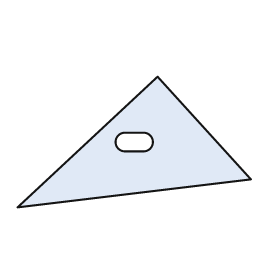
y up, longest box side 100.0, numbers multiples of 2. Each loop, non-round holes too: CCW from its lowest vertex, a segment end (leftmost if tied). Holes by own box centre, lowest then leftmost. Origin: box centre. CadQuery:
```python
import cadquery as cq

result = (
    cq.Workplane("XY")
    .moveTo(-50.0, -28.0)
    .lineTo(50.0, -16.0)
    .lineTo(10.0, 28.0)
    .close()
    .moveTo(-4.0, -4.0)
    .lineTo(4.0, -4.0)
    .threePointArc((8.0, 0.0), (4.0, 4.0))
    .lineTo(-4.0, 4.0)
    .threePointArc((-8.0, 0.0), (-4.0, -4.0))
    .close()
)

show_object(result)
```